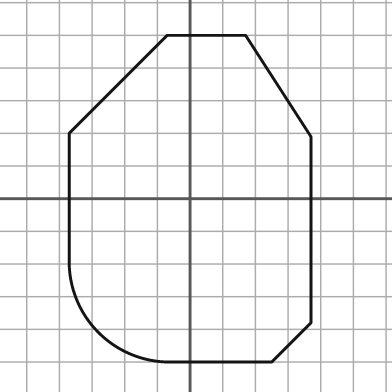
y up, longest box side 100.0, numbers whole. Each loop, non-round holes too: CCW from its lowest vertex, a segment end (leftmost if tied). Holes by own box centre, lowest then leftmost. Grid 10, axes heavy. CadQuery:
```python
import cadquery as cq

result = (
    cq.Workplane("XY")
    .moveTo(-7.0, -50.0)
    .lineTo(25.0, -50.0)
    .lineTo(37.0, -38.0)
    .lineTo(37.0, 19.0)
    .lineTo(17.0, 50.0)
    .lineTo(-7.0, 50.0)
    .lineTo(-37.0, 20.0)
    .lineTo(-37.0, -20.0)
    .threePointArc((-28.0, -41.0), (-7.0, -50.0))
    .close()
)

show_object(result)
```